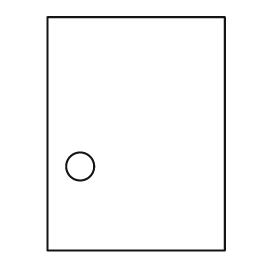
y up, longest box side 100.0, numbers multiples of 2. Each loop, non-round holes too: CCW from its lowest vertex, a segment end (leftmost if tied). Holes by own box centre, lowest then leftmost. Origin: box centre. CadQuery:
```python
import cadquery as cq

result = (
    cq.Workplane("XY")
    .moveTo(-38.0, -50.0)
    .lineTo(38.0, -50.0)
    .lineTo(38.0, 50.0)
    .lineTo(-38.0, 50.0)
    .close()
    .moveTo(-24.0, -14.0)
    .circle(6.0)
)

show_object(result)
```